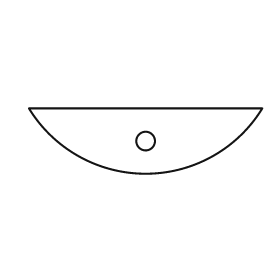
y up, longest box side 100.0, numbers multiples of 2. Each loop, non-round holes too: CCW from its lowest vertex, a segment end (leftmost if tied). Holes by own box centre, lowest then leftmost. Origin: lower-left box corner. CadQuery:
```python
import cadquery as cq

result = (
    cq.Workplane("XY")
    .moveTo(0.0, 28.0)
    .threePointArc((50.0, 0.0), (100.0, 28.0))
    .close()
    .moveTo(50.0, 14.0)
    .circle(4.0)
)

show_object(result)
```